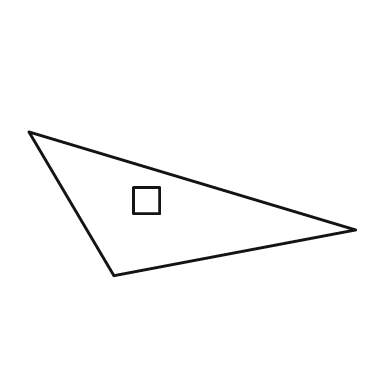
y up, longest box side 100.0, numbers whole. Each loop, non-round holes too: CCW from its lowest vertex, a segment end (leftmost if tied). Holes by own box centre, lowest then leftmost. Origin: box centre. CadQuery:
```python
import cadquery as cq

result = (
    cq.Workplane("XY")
    .moveTo(-24.0, -22.0)
    .lineTo(50.0, -8.0)
    .lineTo(-50.0, 22.0)
    .close()
    .moveTo(-18.0, -3.0)
    .lineTo(-10.0, -3.0)
    .lineTo(-10.0, 5.0)
    .lineTo(-18.0, 5.0)
    .close()
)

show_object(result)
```